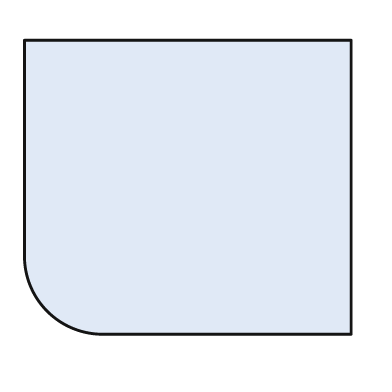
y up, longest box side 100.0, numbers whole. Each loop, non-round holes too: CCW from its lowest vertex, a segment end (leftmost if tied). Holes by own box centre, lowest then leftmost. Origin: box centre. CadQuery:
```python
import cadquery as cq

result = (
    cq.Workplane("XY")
    .moveTo(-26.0, -45.0)
    .lineTo(50.0, -45.0)
    .lineTo(50.0, 45.0)
    .lineTo(-50.0, 45.0)
    .lineTo(-50.0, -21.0)
    .threePointArc((-43.0, -38.0), (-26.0, -45.0))
    .close()
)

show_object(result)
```